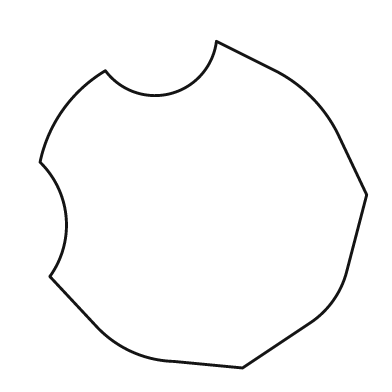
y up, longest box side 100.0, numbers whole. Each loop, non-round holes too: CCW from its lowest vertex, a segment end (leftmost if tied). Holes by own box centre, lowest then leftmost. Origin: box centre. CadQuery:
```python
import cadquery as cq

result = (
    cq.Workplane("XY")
    .moveTo(12.0, -50.0)
    .lineTo(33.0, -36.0)
    .threePointArc((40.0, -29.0), (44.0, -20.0))
    .lineTo(50.0, 3.0)
    .lineTo(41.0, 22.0)
    .threePointArc((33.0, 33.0), (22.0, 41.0))
    .lineTo(4.0, 50.0)
    .threePointArc((-10.0, 34.0), (-30.0, 41.0))
    .threePointArc((-43.0, 29.0), (-50.0, 13.0))
    .threePointArc((-42.0, -4.0), (-47.0, -22.0))
    .lineTo(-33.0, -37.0)
    .threePointArc((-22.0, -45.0), (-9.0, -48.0))
    .close()
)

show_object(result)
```